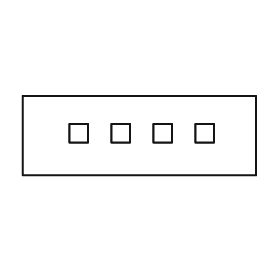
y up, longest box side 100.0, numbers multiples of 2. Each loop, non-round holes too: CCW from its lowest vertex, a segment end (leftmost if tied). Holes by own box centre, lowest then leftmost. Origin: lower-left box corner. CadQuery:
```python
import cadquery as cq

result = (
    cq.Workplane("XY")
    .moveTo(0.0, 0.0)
    .lineTo(100.0, 0.0)
    .lineTo(100.0, 34.0)
    .lineTo(0.0, 34.0)
    .close()
    .moveTo(20.0, 14.0)
    .lineTo(28.0, 14.0)
    .lineTo(28.0, 22.0)
    .lineTo(20.0, 22.0)
    .close()
    .moveTo(38.0, 14.0)
    .lineTo(46.0, 14.0)
    .lineTo(46.0, 22.0)
    .lineTo(38.0, 22.0)
    .close()
    .moveTo(56.0, 14.0)
    .lineTo(64.0, 14.0)
    .lineTo(64.0, 22.0)
    .lineTo(56.0, 22.0)
    .close()
    .moveTo(74.0, 14.0)
    .lineTo(82.0, 14.0)
    .lineTo(82.0, 22.0)
    .lineTo(74.0, 22.0)
    .close()
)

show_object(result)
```